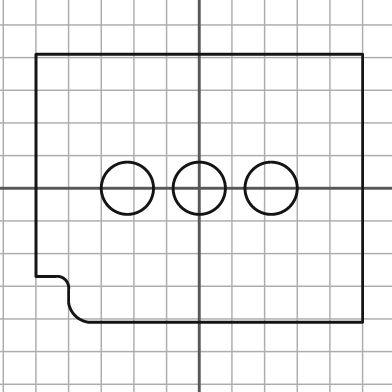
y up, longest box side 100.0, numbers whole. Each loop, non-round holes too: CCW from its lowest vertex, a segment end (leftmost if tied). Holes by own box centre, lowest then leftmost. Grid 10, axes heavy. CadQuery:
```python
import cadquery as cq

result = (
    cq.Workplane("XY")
    .moveTo(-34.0, -41.0)
    .lineTo(50.0, -41.0)
    .lineTo(50.0, 41.0)
    .lineTo(-50.0, 41.0)
    .lineTo(-50.0, -27.0)
    .lineTo(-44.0, -27.0)
    .threePointArc((-41.0, -28.0), (-40.0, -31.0))
    .lineTo(-40.0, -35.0)
    .threePointArc((-38.0, -39.0), (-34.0, -41.0))
    .close()
    .moveTo(-22.0, 0.0)
    .circle(8.0)
    .moveTo(0.0, 0.0)
    .circle(8.0)
    .moveTo(22.0, 0.0)
    .circle(8.0)
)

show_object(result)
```